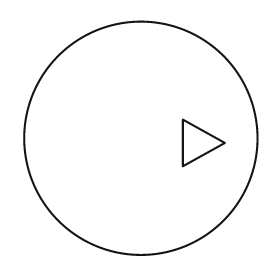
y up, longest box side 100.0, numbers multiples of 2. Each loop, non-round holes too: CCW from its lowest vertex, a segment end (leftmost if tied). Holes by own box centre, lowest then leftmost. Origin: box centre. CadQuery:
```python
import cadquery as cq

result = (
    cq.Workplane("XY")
    .moveTo(0.0, 0.0)
    .circle(50.0)
    .moveTo(18.0, -12.0)
    .lineTo(36.0, -2.0)
    .lineTo(18.0, 8.0)
    .close()
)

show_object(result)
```